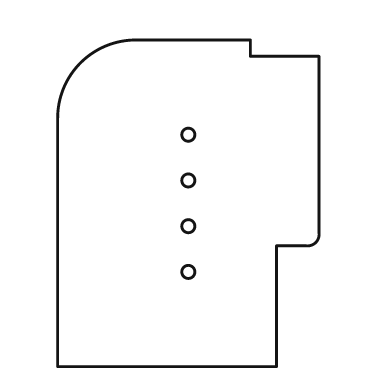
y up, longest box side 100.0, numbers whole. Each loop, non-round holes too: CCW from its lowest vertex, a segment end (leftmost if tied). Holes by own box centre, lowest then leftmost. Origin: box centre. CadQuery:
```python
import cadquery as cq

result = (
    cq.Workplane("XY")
    .moveTo(-40.0, -50.0)
    .lineTo(27.0, -50.0)
    .lineTo(27.0, -13.0)
    .lineTo(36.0, -13.0)
    .threePointArc((39.0, -12.0), (40.0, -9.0))
    .lineTo(40.0, 45.0)
    .lineTo(19.0, 45.0)
    .lineTo(19.0, 50.0)
    .lineTo(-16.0, 50.0)
    .threePointArc((-33.0, 43.0), (-40.0, 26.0))
    .close()
    .moveTo(0.0, -21.0)
    .circle(2.0)
    .moveTo(0.0, -7.0)
    .circle(2.0)
    .moveTo(0.0, 7.0)
    .circle(2.0)
    .moveTo(0.0, 21.0)
    .circle(2.0)
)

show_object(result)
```